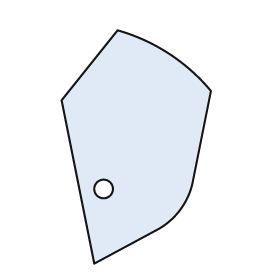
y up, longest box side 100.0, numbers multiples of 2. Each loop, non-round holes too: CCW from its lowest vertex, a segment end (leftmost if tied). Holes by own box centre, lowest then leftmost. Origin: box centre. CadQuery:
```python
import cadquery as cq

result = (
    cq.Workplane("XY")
    .moveTo(-18.0, -50.0)
    .lineTo(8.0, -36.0)
    .threePointArc((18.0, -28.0), (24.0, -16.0))
    .lineTo(32.0, 24.0)
    .threePointArc((14.0, 40.0), (-8.0, 50.0))
    .lineTo(-32.0, 20.0)
    .close()
    .moveTo(-14.0, -18.0)
    .circle(4.0)
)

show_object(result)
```